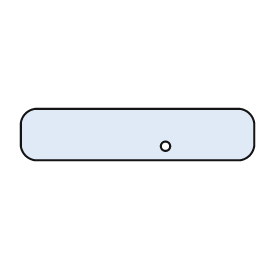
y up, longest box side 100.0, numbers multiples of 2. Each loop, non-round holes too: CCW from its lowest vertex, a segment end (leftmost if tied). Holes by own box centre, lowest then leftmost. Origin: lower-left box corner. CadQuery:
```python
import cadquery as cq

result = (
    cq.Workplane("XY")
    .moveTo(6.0, 0.0)
    .lineTo(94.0, 0.0)
    .threePointArc((98.0, 2.0), (100.0, 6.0))
    .lineTo(100.0, 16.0)
    .threePointArc((98.0, 20.0), (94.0, 22.0))
    .lineTo(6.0, 22.0)
    .threePointArc((2.0, 20.0), (0.0, 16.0))
    .lineTo(0.0, 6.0)
    .threePointArc((2.0, 2.0), (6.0, 0.0))
    .close()
    .moveTo(62.0, 6.0)
    .circle(2.0)
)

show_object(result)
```